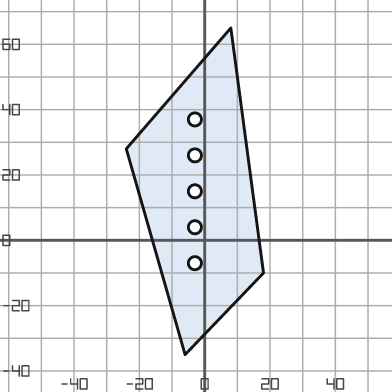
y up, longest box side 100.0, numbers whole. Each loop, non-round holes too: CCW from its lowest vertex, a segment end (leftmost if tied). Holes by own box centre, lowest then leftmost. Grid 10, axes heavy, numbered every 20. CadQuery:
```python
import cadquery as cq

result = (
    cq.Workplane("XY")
    .moveTo(-6.0, -35.0)
    .lineTo(18.0, -10.0)
    .lineTo(8.0, 65.0)
    .lineTo(-24.0, 28.0)
    .close()
    .moveTo(-3.0, -7.0)
    .circle(2.0)
    .moveTo(-3.0, 4.0)
    .circle(2.0)
    .moveTo(-3.0, 15.0)
    .circle(2.0)
    .moveTo(-3.0, 26.0)
    .circle(2.0)
    .moveTo(-3.0, 37.0)
    .circle(2.0)
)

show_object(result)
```